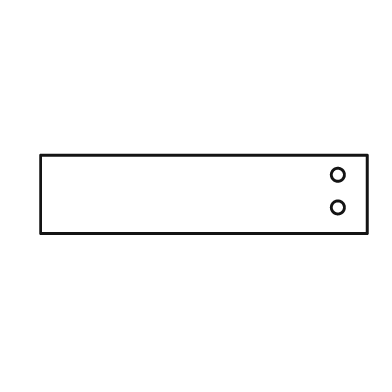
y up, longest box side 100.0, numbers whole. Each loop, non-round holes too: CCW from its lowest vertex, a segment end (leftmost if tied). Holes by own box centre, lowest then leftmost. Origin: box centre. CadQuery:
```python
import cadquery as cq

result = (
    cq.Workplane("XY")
    .moveTo(-50.0, -12.0)
    .lineTo(50.0, -12.0)
    .lineTo(50.0, 12.0)
    .lineTo(-50.0, 12.0)
    .close()
    .moveTo(41.0, -4.0)
    .circle(2.0)
    .moveTo(41.0, 6.0)
    .circle(2.0)
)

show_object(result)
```